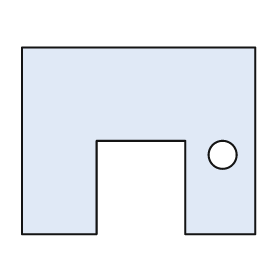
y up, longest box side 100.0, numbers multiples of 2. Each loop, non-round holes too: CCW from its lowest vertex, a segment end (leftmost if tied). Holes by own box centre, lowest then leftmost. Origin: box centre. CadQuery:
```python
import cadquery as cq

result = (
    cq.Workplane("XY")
    .moveTo(-50.0, -40.0)
    .lineTo(-18.0, -40.0)
    .lineTo(-18.0, 0.0)
    .lineTo(20.0, 0.0)
    .lineTo(20.0, -40.0)
    .lineTo(50.0, -40.0)
    .lineTo(50.0, 40.0)
    .lineTo(-50.0, 40.0)
    .close()
    .moveTo(36.0, -6.0)
    .circle(6.0)
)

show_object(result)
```